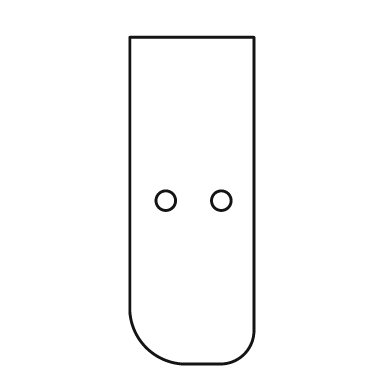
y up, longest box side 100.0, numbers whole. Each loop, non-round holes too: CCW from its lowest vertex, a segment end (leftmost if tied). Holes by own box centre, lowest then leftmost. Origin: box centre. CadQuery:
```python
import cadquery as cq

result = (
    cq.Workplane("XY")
    .moveTo(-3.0, -50.0)
    .lineTo(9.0, -50.0)
    .threePointArc((16.0, -47.0), (19.0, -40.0))
    .lineTo(19.0, 50.0)
    .lineTo(-19.0, 50.0)
    .lineTo(-19.0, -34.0)
    .threePointArc((-14.0, -45.0), (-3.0, -50.0))
    .close()
    .moveTo(-8.0, 0.0)
    .circle(3.0)
    .moveTo(9.0, 0.0)
    .circle(3.0)
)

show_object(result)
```